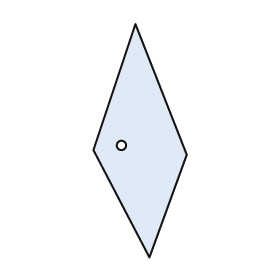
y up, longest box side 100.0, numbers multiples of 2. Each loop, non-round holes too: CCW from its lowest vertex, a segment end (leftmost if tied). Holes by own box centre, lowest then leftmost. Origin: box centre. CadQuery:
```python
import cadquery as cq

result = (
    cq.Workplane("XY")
    .moveTo(4.0, -50.0)
    .lineTo(20.0, -6.0)
    .lineTo(-2.0, 50.0)
    .lineTo(-20.0, -4.0)
    .close()
    .moveTo(-8.0, -2.0)
    .circle(2.0)
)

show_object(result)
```